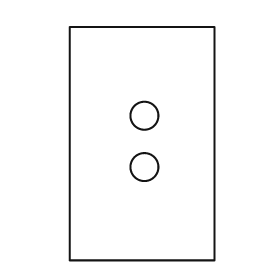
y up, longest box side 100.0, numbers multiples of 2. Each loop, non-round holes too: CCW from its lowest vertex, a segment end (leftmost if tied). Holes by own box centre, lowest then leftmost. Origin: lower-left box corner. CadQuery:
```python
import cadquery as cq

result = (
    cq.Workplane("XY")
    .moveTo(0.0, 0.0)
    .lineTo(62.0, 0.0)
    .lineTo(62.0, 100.0)
    .lineTo(0.0, 100.0)
    .close()
    .moveTo(32.0, 40.0)
    .circle(6.0)
    .moveTo(32.0, 62.0)
    .circle(6.0)
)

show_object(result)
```